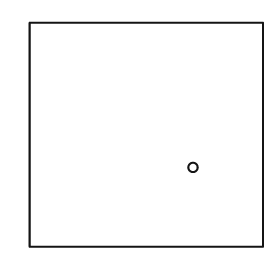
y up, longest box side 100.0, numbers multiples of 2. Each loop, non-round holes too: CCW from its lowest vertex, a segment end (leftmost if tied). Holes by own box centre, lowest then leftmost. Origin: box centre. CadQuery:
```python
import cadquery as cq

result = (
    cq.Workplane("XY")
    .moveTo(-50.0, -48.0)
    .lineTo(50.0, -48.0)
    .lineTo(50.0, 48.0)
    .lineTo(-50.0, 48.0)
    .close()
    .moveTo(20.0, -14.0)
    .circle(2.0)
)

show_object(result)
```